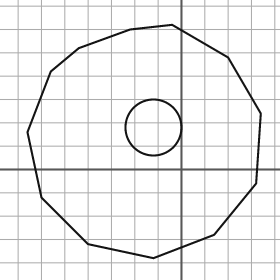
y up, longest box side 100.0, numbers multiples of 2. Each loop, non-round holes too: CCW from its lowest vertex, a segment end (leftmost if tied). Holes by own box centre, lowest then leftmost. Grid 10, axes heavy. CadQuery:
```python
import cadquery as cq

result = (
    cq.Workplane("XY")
    .moveTo(-12.0, -38.0)
    .lineTo(14.0, -28.0)
    .lineTo(32.0, -6.0)
    .lineTo(34.0, 24.0)
    .lineTo(20.0, 48.0)
    .lineTo(-4.0, 62.0)
    .lineTo(-22.0, 60.0)
    .lineTo(-44.0, 52.0)
    .lineTo(-56.0, 42.0)
    .lineTo(-66.0, 16.0)
    .lineTo(-60.0, -12.0)
    .lineTo(-40.0, -32.0)
    .close()
    .moveTo(-12.0, 18.0)
    .circle(12.0)
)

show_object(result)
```